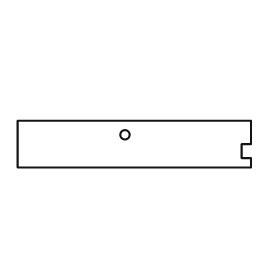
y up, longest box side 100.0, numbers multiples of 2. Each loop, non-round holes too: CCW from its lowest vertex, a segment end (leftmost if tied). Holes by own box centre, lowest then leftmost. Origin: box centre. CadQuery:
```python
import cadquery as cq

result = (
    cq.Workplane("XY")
    .moveTo(-50.0, -10.0)
    .lineTo(50.0, -10.0)
    .lineTo(50.0, -6.0)
    .lineTo(46.0, -6.0)
    .lineTo(46.0, 0.0)
    .lineTo(50.0, 0.0)
    .lineTo(50.0, 10.0)
    .lineTo(-50.0, 10.0)
    .close()
    .moveTo(-4.0, 4.0)
    .circle(2.0)
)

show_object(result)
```